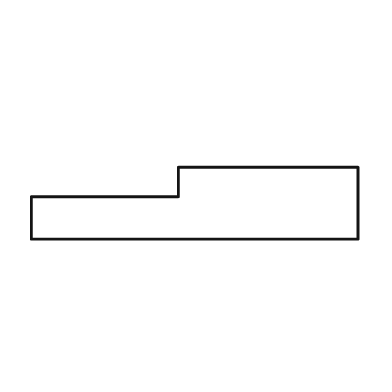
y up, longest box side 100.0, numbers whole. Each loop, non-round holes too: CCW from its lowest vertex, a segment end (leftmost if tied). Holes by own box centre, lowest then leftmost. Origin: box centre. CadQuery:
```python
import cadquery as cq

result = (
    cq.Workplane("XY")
    .moveTo(-50.0, -11.0)
    .lineTo(50.0, -11.0)
    .lineTo(50.0, 11.0)
    .lineTo(-5.0, 11.0)
    .lineTo(-5.0, 2.0)
    .lineTo(-50.0, 2.0)
    .close()
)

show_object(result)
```